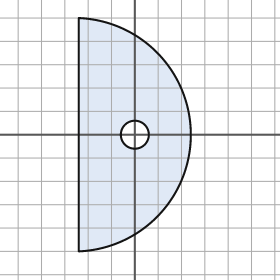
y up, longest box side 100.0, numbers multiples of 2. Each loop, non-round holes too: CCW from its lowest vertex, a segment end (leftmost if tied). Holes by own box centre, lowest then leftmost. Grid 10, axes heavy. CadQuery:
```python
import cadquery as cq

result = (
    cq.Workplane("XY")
    .moveTo(-24.0, -50.0)
    .threePointArc((24.0, 0.0), (-24.0, 50.0))
    .close()
    .moveTo(0.0, 0.0)
    .circle(6.0)
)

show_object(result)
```